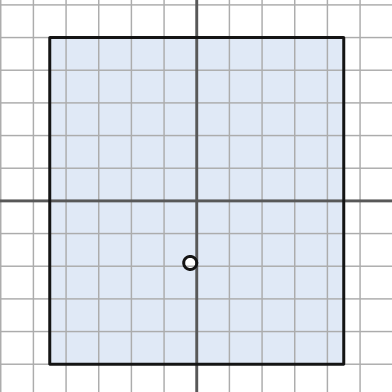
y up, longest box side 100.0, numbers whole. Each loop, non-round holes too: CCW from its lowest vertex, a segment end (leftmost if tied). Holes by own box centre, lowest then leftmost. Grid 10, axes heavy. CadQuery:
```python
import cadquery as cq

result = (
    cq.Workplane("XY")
    .moveTo(-45.0, -50.0)
    .lineTo(45.0, -50.0)
    .lineTo(45.0, 50.0)
    .lineTo(-45.0, 50.0)
    .close()
    .moveTo(-2.0, -19.0)
    .circle(2.0)
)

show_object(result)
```